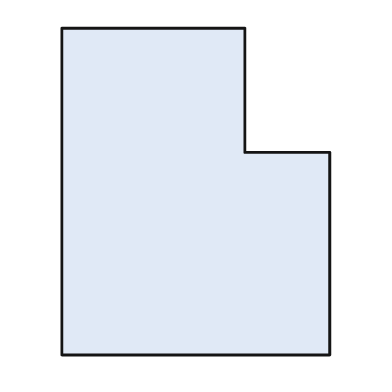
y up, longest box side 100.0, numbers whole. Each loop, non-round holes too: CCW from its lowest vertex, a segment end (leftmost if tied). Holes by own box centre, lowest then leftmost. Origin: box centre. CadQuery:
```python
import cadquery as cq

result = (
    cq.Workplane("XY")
    .moveTo(-41.0, -50.0)
    .lineTo(41.0, -50.0)
    .lineTo(41.0, 12.0)
    .lineTo(15.0, 12.0)
    .lineTo(15.0, 50.0)
    .lineTo(-41.0, 50.0)
    .close()
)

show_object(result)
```